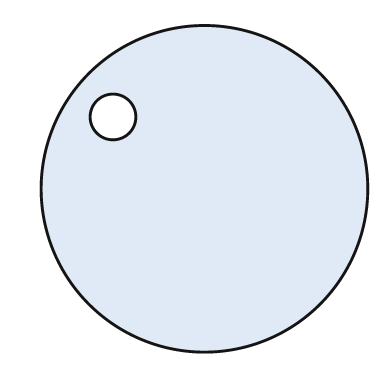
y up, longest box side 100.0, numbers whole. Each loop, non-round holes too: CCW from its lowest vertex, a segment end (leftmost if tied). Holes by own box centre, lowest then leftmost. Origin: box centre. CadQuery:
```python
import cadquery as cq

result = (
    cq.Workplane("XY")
    .moveTo(0.0, 0.0)
    .circle(50.0)
    .moveTo(-28.0, 22.0)
    .circle(7.0)
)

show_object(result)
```